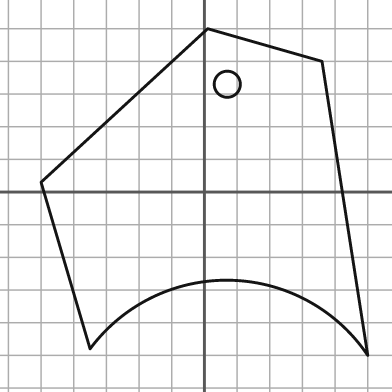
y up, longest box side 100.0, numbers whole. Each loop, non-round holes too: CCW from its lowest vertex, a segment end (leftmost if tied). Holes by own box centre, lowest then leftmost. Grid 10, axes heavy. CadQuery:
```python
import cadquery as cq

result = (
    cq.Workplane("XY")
    .moveTo(50.0, -50.0)
    .lineTo(36.0, 40.0)
    .lineTo(1.0, 50.0)
    .lineTo(-50.0, 3.0)
    .lineTo(-35.0, -48.0)
    .threePointArc((8.0, -27.0), (50.0, -50.0))
    .close()
    .moveTo(7.0, 33.0)
    .circle(4.0)
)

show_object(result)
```